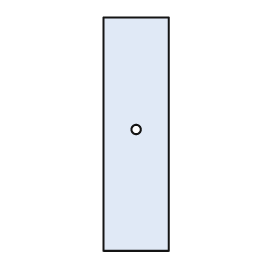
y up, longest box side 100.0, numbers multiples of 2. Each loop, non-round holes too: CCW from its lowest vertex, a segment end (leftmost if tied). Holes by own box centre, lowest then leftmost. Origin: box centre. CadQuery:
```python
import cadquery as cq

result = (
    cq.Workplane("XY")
    .moveTo(-14.0, -50.0)
    .lineTo(14.0, -50.0)
    .lineTo(14.0, 50.0)
    .lineTo(-14.0, 50.0)
    .close()
    .moveTo(0.0, 2.0)
    .circle(2.0)
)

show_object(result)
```